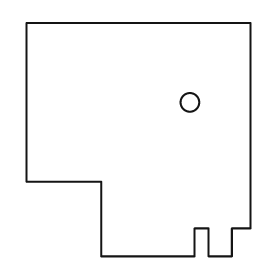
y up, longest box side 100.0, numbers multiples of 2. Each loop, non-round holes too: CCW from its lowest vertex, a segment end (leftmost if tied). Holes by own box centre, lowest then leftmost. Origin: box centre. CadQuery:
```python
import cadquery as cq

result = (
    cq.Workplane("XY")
    .moveTo(-16.0, -50.0)
    .lineTo(24.0, -50.0)
    .lineTo(24.0, -38.0)
    .lineTo(30.0, -38.0)
    .lineTo(30.0, -50.0)
    .lineTo(40.0, -50.0)
    .lineTo(40.0, -38.0)
    .lineTo(48.0, -38.0)
    .lineTo(48.0, 50.0)
    .lineTo(-48.0, 50.0)
    .lineTo(-48.0, -18.0)
    .lineTo(-16.0, -18.0)
    .close()
    .moveTo(22.0, 16.0)
    .circle(4.0)
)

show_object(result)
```